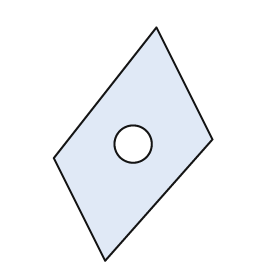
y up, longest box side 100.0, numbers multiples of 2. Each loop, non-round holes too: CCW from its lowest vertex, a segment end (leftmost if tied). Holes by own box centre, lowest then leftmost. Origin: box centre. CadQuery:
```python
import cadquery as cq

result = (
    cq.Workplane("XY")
    .moveTo(-12.0, -50.0)
    .lineTo(34.0, 2.0)
    .lineTo(10.0, 50.0)
    .lineTo(-34.0, -6.0)
    .close()
    .moveTo(0.0, 0.0)
    .circle(8.0)
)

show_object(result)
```